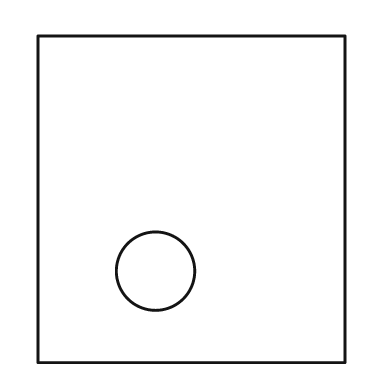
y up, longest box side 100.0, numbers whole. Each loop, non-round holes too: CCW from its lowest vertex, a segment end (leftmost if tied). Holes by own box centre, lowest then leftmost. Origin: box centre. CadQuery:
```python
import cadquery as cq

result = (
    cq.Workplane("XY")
    .moveTo(-47.0, -50.0)
    .lineTo(47.0, -50.0)
    .lineTo(47.0, 50.0)
    .lineTo(-47.0, 50.0)
    .close()
    .moveTo(-11.0, -22.0)
    .circle(12.0)
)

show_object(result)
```